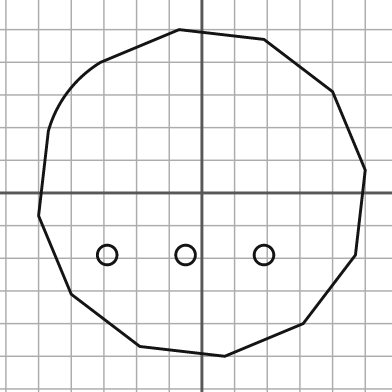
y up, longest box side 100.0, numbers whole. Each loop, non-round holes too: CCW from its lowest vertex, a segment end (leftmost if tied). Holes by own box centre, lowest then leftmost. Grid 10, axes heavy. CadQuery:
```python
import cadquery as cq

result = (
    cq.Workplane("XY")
    .moveTo(7.0, -50.0)
    .lineTo(31.0, -40.0)
    .lineTo(47.0, -19.0)
    .lineTo(50.0, 7.0)
    .lineTo(40.0, 31.0)
    .lineTo(19.0, 47.0)
    .lineTo(-7.0, 50.0)
    .lineTo(-31.0, 40.0)
    .threePointArc((-41.0, 31.0), (-47.0, 19.0))
    .lineTo(-50.0, -7.0)
    .lineTo(-40.0, -31.0)
    .lineTo(-19.0, -47.0)
    .close()
    .moveTo(-29.0, -19.0)
    .circle(3.0)
    .moveTo(-5.0, -19.0)
    .circle(3.0)
    .moveTo(19.0, -19.0)
    .circle(3.0)
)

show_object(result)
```